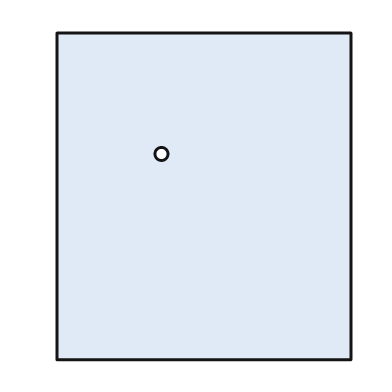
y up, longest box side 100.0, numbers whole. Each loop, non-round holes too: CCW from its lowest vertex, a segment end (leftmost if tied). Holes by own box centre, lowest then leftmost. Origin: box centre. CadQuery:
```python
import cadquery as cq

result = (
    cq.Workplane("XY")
    .moveTo(-45.0, -50.0)
    .lineTo(45.0, -50.0)
    .lineTo(45.0, 50.0)
    .lineTo(-45.0, 50.0)
    .close()
    .moveTo(-13.0, 13.0)
    .circle(2.0)
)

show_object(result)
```